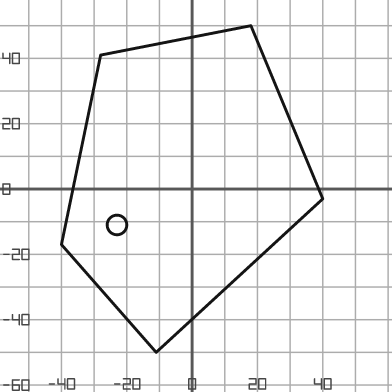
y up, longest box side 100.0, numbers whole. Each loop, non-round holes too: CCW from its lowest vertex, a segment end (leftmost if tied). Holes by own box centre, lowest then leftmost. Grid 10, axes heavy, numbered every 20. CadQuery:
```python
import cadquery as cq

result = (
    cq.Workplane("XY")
    .moveTo(-11.0, -50.0)
    .lineTo(40.0, -3.0)
    .lineTo(18.0, 50.0)
    .lineTo(-28.0, 41.0)
    .lineTo(-40.0, -17.0)
    .close()
    .moveTo(-23.0, -11.0)
    .circle(3.0)
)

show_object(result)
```